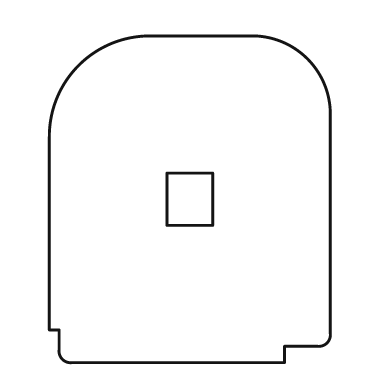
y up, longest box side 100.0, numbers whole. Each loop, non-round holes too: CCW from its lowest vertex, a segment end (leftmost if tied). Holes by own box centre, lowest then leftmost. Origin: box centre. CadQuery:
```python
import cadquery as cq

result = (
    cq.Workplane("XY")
    .moveTo(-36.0, -50.0)
    .lineTo(29.0, -50.0)
    .lineTo(29.0, -45.0)
    .lineTo(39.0, -45.0)
    .threePointArc((42.0, -44.0), (43.0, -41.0))
    .lineTo(43.0, 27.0)
    .threePointArc((36.0, 43.0), (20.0, 50.0))
    .lineTo(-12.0, 50.0)
    .threePointArc((-34.0, 41.0), (-43.0, 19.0))
    .lineTo(-43.0, -40.0)
    .lineTo(-40.0, -40.0)
    .lineTo(-40.0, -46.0)
    .threePointArc((-39.0, -49.0), (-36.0, -50.0))
    .close()
    .moveTo(-7.0, -8.0)
    .lineTo(7.0, -8.0)
    .lineTo(7.0, 8.0)
    .lineTo(-7.0, 8.0)
    .close()
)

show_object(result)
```